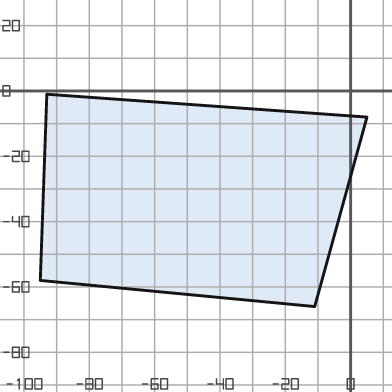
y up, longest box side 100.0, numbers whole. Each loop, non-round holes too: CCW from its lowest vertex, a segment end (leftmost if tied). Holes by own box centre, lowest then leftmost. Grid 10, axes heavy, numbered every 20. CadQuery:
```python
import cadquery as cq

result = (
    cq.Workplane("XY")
    .moveTo(-11.0, -66.0)
    .lineTo(5.0, -8.0)
    .lineTo(-93.0, -1.0)
    .lineTo(-95.0, -58.0)
    .close()
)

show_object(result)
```